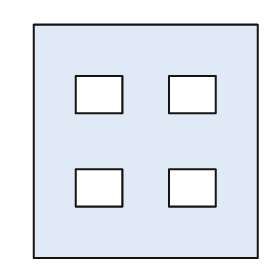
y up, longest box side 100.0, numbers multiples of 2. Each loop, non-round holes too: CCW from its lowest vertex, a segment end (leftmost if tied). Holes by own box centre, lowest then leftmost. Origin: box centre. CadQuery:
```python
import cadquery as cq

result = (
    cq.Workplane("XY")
    .moveTo(-48.0, -50.0)
    .lineTo(48.0, -50.0)
    .lineTo(48.0, 50.0)
    .lineTo(-48.0, 50.0)
    .close()
    .moveTo(-30.0, -28.0)
    .lineTo(-10.0, -28.0)
    .lineTo(-10.0, -12.0)
    .lineTo(-30.0, -12.0)
    .close()
    .moveTo(10.0, -28.0)
    .lineTo(30.0, -28.0)
    .lineTo(30.0, -12.0)
    .lineTo(10.0, -12.0)
    .close()
    .moveTo(-30.0, 12.0)
    .lineTo(-10.0, 12.0)
    .lineTo(-10.0, 28.0)
    .lineTo(-30.0, 28.0)
    .close()
    .moveTo(10.0, 12.0)
    .lineTo(30.0, 12.0)
    .lineTo(30.0, 28.0)
    .lineTo(10.0, 28.0)
    .close()
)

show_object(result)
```